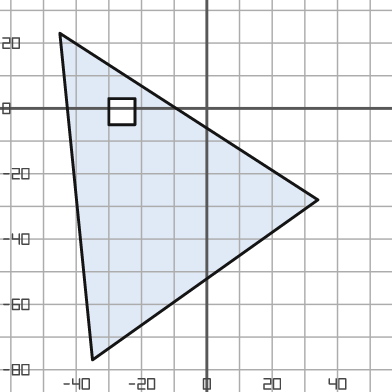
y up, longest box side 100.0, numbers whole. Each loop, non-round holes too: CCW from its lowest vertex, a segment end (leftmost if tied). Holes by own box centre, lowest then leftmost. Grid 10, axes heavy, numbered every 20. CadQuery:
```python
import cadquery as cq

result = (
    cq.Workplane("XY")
    .moveTo(-35.0, -77.0)
    .lineTo(34.0, -28.0)
    .lineTo(-45.0, 23.0)
    .close()
    .moveTo(-30.0, -5.0)
    .lineTo(-22.0, -5.0)
    .lineTo(-22.0, 3.0)
    .lineTo(-30.0, 3.0)
    .close()
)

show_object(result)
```